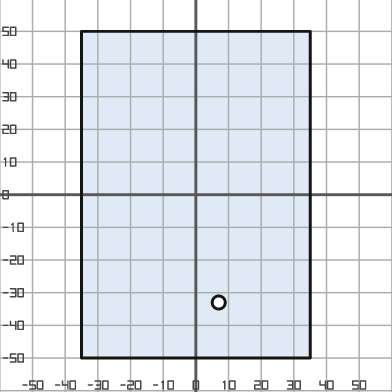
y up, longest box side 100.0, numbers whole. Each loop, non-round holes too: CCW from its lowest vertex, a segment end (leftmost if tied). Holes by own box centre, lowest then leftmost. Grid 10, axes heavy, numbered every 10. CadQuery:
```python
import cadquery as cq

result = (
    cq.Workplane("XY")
    .moveTo(-35.0, -50.0)
    .lineTo(35.0, -50.0)
    .lineTo(35.0, 50.0)
    .lineTo(-35.0, 50.0)
    .close()
    .moveTo(7.0, -33.0)
    .circle(2.0)
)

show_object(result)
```